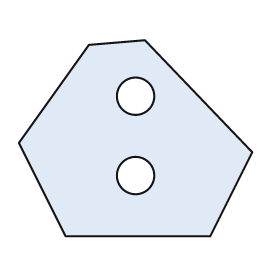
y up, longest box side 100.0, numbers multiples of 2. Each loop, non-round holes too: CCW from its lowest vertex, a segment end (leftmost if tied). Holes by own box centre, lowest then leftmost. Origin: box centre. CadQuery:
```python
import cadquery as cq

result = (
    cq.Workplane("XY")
    .moveTo(-30.0, -42.0)
    .lineTo(32.0, -42.0)
    .lineTo(50.0, -6.0)
    .lineTo(4.0, 42.0)
    .lineTo(-20.0, 40.0)
    .lineTo(-50.0, -2.0)
    .close()
    .moveTo(0.0, -16.0)
    .circle(8.0)
    .moveTo(0.0, 18.0)
    .circle(8.0)
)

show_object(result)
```